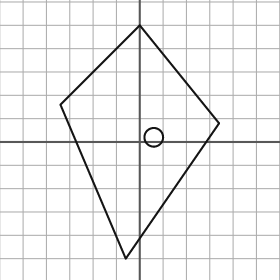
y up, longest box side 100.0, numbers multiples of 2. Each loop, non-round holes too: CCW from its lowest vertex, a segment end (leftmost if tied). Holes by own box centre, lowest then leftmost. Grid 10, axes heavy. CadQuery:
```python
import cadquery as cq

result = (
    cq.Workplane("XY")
    .moveTo(-6.0, -50.0)
    .lineTo(34.0, 8.0)
    .lineTo(0.0, 50.0)
    .lineTo(-34.0, 16.0)
    .close()
    .moveTo(6.0, 2.0)
    .circle(4.0)
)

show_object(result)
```